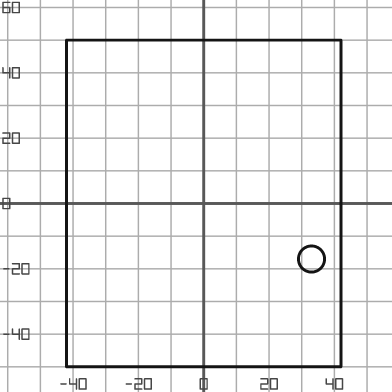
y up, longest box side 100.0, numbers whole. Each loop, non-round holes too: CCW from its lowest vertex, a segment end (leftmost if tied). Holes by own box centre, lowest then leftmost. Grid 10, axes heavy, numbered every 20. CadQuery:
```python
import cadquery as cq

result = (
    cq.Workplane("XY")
    .moveTo(-42.0, -50.0)
    .lineTo(42.0, -50.0)
    .lineTo(42.0, 50.0)
    .lineTo(-42.0, 50.0)
    .close()
    .moveTo(33.0, -17.0)
    .circle(4.0)
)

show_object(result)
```